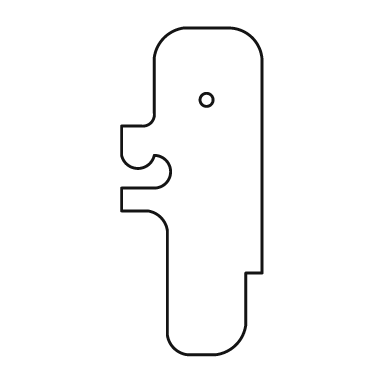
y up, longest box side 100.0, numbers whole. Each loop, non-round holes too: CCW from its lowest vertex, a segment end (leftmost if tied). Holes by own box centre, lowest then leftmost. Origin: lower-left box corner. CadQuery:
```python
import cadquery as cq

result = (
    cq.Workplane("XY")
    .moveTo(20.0, 0.0)
    .lineTo(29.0, 0.0)
    .threePointArc((35.0, 3.0), (38.0, 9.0))
    .lineTo(38.0, 25.0)
    .lineTo(43.0, 25.0)
    .lineTo(43.0, 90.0)
    .threePointArc((40.0, 97.0), (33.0, 100.0))
    .lineTo(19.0, 100.0)
    .threePointArc((13.0, 97.0), (10.0, 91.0))
    .lineTo(10.0, 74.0)
    .threePointArc((9.0, 71.0), (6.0, 70.0))
    .lineTo(0.0, 70.0)
    .lineTo(0.0, 61.0)
    .threePointArc((5.0, 57.0), (10.0, 61.0))
    .threePointArc((15.0, 56.0), (10.0, 51.0))
    .lineTo(0.0, 51.0)
    .lineTo(0.0, 44.0)
    .lineTo(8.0, 44.0)
    .threePointArc((12.0, 42.0), (14.0, 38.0))
    .lineTo(14.0, 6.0)
    .threePointArc((16.0, 2.0), (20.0, 0.0))
    .close()
    .moveTo(26.0, 78.0)
    .circle(2.0)
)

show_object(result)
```